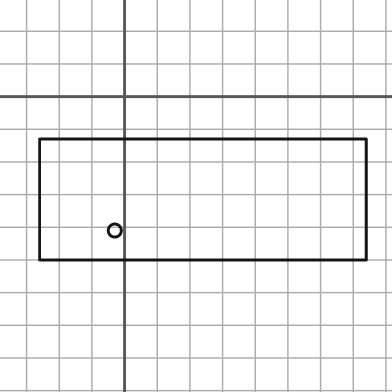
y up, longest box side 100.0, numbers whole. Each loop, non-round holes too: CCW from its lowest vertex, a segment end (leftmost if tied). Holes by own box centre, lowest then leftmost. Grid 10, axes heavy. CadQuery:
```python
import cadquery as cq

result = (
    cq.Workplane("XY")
    .moveTo(-26.0, -50.0)
    .lineTo(74.0, -50.0)
    .lineTo(74.0, -13.0)
    .lineTo(-26.0, -13.0)
    .close()
    .moveTo(-3.0, -41.0)
    .circle(2.0)
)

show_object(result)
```